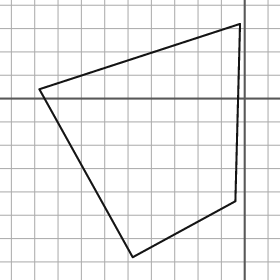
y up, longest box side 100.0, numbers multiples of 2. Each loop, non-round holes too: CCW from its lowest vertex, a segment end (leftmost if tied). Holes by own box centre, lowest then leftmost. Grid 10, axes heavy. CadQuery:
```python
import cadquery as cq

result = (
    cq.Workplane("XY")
    .moveTo(-48.0, -68.0)
    .lineTo(-4.0, -44.0)
    .lineTo(-2.0, 32.0)
    .lineTo(-88.0, 4.0)
    .close()
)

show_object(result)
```